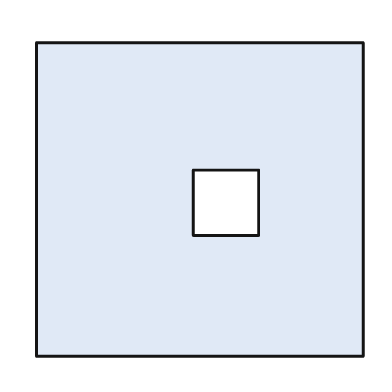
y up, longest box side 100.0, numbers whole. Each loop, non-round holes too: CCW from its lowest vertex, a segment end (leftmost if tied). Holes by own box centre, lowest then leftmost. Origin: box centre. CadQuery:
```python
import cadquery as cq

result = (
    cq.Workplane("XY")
    .moveTo(-50.0, -48.0)
    .lineTo(50.0, -48.0)
    .lineTo(50.0, 48.0)
    .lineTo(-50.0, 48.0)
    .close()
    .moveTo(-2.0, -11.0)
    .lineTo(18.0, -11.0)
    .lineTo(18.0, 9.0)
    .lineTo(-2.0, 9.0)
    .close()
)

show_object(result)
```